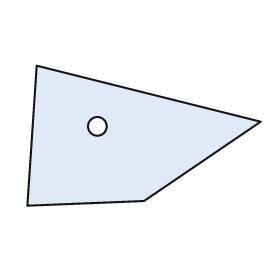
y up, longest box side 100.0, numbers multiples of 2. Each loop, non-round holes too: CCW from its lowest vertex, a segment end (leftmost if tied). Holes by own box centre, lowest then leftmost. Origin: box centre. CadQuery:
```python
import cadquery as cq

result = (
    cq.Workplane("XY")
    .moveTo(-50.0, -30.0)
    .lineTo(0.0, -28.0)
    .lineTo(50.0, 6.0)
    .lineTo(-46.0, 30.0)
    .close()
    .moveTo(-20.0, 4.0)
    .circle(4.0)
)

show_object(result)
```